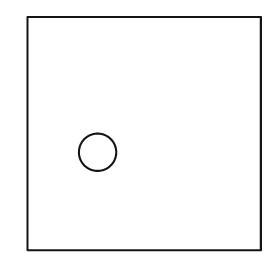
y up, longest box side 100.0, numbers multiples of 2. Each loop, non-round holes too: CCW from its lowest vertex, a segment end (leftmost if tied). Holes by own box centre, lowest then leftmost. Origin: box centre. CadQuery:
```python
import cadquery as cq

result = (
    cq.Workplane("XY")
    .moveTo(-50.0, -50.0)
    .lineTo(50.0, -50.0)
    .lineTo(50.0, 50.0)
    .lineTo(-50.0, 50.0)
    .close()
    .moveTo(-20.0, -8.0)
    .circle(8.0)
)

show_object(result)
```